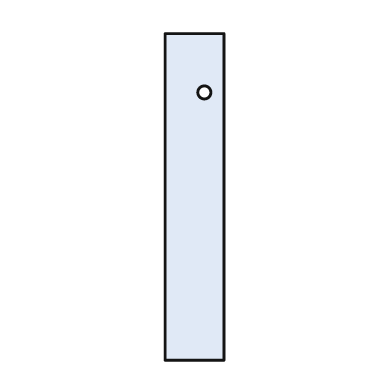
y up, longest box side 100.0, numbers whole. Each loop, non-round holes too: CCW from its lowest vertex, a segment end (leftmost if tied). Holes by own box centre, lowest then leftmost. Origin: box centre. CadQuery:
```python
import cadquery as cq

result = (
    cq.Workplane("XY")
    .moveTo(-9.0, -50.0)
    .lineTo(9.0, -50.0)
    .lineTo(9.0, 50.0)
    .lineTo(-9.0, 50.0)
    .close()
    .moveTo(3.0, 32.0)
    .circle(2.0)
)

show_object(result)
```